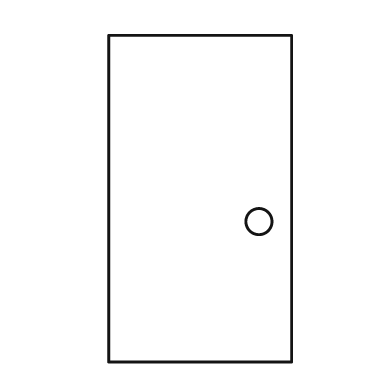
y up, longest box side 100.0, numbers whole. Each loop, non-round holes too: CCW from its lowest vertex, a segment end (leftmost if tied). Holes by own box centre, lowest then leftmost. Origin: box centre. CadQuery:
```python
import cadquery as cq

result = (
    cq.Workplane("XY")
    .moveTo(-28.0, -50.0)
    .lineTo(28.0, -50.0)
    .lineTo(28.0, 50.0)
    .lineTo(-28.0, 50.0)
    .close()
    .moveTo(18.0, -7.0)
    .circle(4.0)
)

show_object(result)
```